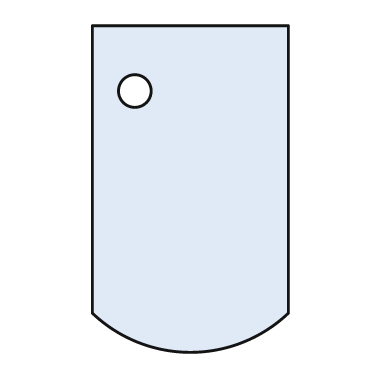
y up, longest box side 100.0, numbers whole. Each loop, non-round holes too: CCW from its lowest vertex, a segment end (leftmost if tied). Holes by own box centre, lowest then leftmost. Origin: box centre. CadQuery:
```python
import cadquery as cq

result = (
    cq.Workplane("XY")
    .moveTo(-30.0, -38.0)
    .threePointArc((0.0, -50.0), (30.0, -38.0))
    .lineTo(30.0, 50.0)
    .lineTo(-30.0, 50.0)
    .close()
    .moveTo(-17.0, 30.0)
    .circle(5.0)
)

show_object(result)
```